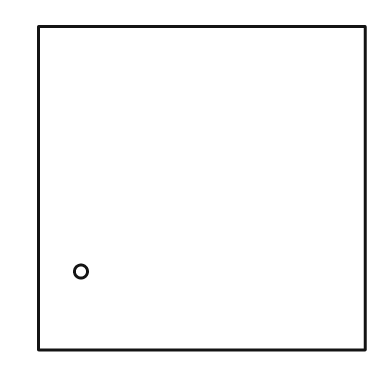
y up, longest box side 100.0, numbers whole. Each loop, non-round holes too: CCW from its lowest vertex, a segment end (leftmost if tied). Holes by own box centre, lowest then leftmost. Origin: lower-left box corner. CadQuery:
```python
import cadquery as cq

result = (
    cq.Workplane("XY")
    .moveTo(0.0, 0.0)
    .lineTo(100.0, 0.0)
    .lineTo(100.0, 99.0)
    .lineTo(0.0, 99.0)
    .close()
    .moveTo(13.0, 24.0)
    .circle(2.0)
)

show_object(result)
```